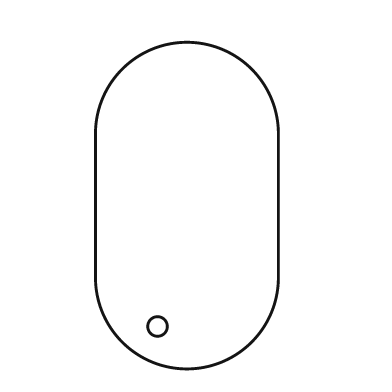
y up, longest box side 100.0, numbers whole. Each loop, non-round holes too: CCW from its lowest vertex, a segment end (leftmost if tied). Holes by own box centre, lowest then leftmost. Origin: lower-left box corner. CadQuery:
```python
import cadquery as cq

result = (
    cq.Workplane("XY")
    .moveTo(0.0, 28.0)
    .threePointArc((28.0, 0.0), (56.0, 28.0))
    .lineTo(56.0, 72.0)
    .threePointArc((28.0, 100.0), (0.0, 72.0))
    .close()
    .moveTo(19.0, 13.0)
    .circle(3.0)
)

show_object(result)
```